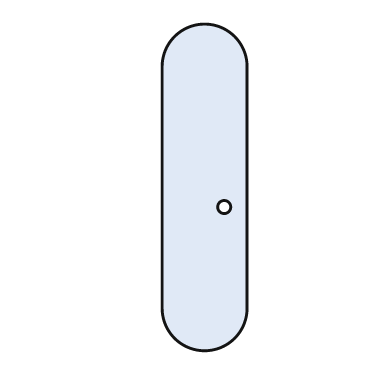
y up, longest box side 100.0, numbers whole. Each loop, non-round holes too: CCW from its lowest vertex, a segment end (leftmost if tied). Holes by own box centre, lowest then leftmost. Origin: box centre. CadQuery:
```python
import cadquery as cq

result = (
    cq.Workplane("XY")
    .moveTo(-13.0, -37.0)
    .threePointArc((0.0, -50.0), (13.0, -37.0))
    .lineTo(13.0, 37.0)
    .threePointArc((0.0, 50.0), (-13.0, 37.0))
    .close()
    .moveTo(6.0, -6.0)
    .circle(2.0)
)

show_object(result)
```